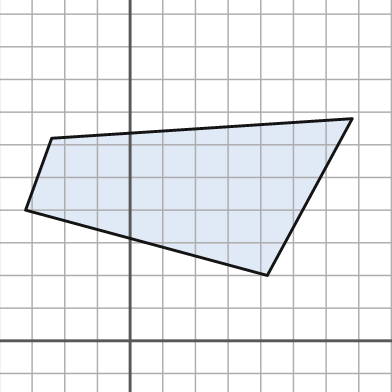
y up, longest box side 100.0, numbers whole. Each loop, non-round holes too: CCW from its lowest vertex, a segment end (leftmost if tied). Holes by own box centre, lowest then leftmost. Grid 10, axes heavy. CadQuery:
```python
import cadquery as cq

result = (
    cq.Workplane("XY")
    .moveTo(42.0, 20.0)
    .lineTo(68.0, 68.0)
    .lineTo(-24.0, 62.0)
    .lineTo(-32.0, 40.0)
    .close()
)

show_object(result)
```